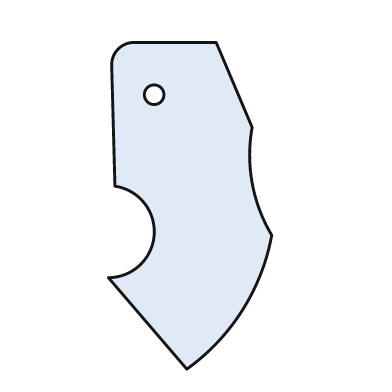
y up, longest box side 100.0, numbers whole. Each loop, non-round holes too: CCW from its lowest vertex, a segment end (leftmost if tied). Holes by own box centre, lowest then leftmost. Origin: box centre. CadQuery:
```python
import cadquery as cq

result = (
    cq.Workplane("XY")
    .moveTo(-1.0, -50.0)
    .threePointArc((16.0, -32.0), (25.0, -9.0))
    .threePointArc((19.0, 7.0), (19.0, 24.0))
    .lineTo(8.0, 50.0)
    .lineTo(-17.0, 50.0)
    .threePointArc((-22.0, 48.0), (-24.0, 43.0))
    .lineTo(-23.0, 6.0)
    .threePointArc((-11.0, -9.0), (-25.0, -22.0))
    .close()
    .moveTo(-11.0, 34.0)
    .circle(3.0)
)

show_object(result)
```